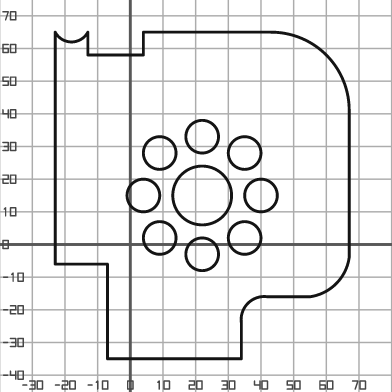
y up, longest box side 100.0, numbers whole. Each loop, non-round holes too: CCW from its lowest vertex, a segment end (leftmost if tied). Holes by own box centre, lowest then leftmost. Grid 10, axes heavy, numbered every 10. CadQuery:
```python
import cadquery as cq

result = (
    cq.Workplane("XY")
    .moveTo(-7.0, -35.0)
    .lineTo(34.0, -35.0)
    .lineTo(34.0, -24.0)
    .threePointArc((36.0, -18.0), (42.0, -16.0))
    .lineTo(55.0, -16.0)
    .threePointArc((63.0, -12.0), (67.0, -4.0))
    .lineTo(67.0, 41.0)
    .threePointArc((60.0, 58.0), (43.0, 65.0))
    .lineTo(4.0, 65.0)
    .lineTo(4.0, 58.0)
    .lineTo(-13.0, 58.0)
    .lineTo(-13.0, 65.0)
    .threePointArc((-18.0, 62.0), (-23.0, 65.0))
    .lineTo(-23.0, -6.0)
    .lineTo(-7.0, -6.0)
    .close()
    .moveTo(22.0, -3.0)
    .circle(5.0)
    .moveTo(9.0, 2.0)
    .circle(5.0)
    .moveTo(35.0, 2.0)
    .circle(5.0)
    .moveTo(4.0, 15.0)
    .circle(5.0)
    .moveTo(22.0, 15.0)
    .circle(9.0)
    .moveTo(40.0, 15.0)
    .circle(5.0)
    .moveTo(9.0, 28.0)
    .circle(5.0)
    .moveTo(35.0, 28.0)
    .circle(5.0)
    .moveTo(22.0, 33.0)
    .circle(5.0)
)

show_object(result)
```